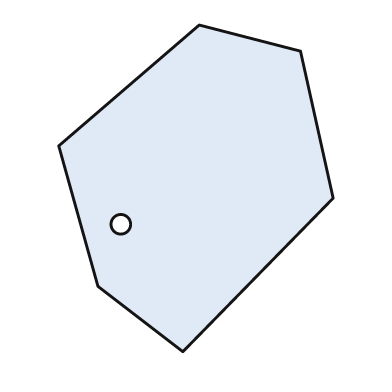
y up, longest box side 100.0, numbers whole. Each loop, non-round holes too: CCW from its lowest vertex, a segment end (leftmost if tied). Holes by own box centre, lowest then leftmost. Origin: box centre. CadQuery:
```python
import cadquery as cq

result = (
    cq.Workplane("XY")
    .moveTo(-4.0, -50.0)
    .lineTo(42.0, -3.0)
    .lineTo(32.0, 42.0)
    .lineTo(1.0, 50.0)
    .lineTo(-42.0, 13.0)
    .lineTo(-30.0, -30.0)
    .close()
    .moveTo(-23.0, -11.0)
    .circle(3.0)
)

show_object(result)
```